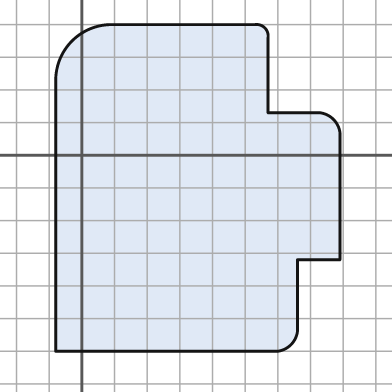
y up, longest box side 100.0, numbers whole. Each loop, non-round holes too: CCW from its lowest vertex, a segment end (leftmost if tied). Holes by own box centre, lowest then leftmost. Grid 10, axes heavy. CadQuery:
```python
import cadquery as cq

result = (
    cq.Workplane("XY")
    .moveTo(-8.0, -60.0)
    .lineTo(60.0, -60.0)
    .threePointArc((64.0, -58.0), (66.0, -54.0))
    .lineTo(66.0, -32.0)
    .lineTo(79.0, -32.0)
    .lineTo(79.0, 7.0)
    .threePointArc((77.0, 11.0), (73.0, 13.0))
    .lineTo(57.0, 13.0)
    .lineTo(57.0, 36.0)
    .threePointArc((56.0, 39.0), (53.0, 40.0))
    .lineTo(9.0, 40.0)
    .threePointArc((-3.0, 35.0), (-8.0, 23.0))
    .close()
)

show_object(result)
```